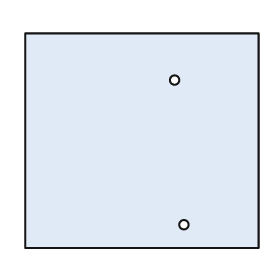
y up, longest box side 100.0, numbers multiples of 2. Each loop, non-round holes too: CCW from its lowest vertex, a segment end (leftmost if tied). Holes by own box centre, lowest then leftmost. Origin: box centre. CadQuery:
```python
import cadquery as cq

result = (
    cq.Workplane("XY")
    .moveTo(-50.0, -46.0)
    .lineTo(50.0, -46.0)
    .lineTo(50.0, 46.0)
    .lineTo(-50.0, 46.0)
    .close()
    .moveTo(18.0, -36.0)
    .circle(2.0)
    .moveTo(14.0, 26.0)
    .circle(2.0)
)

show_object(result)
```